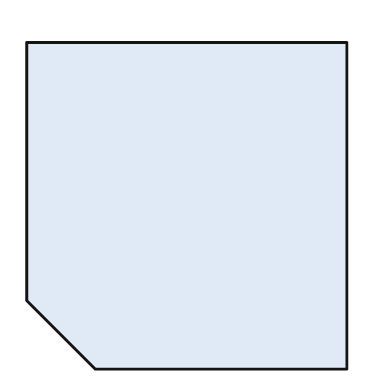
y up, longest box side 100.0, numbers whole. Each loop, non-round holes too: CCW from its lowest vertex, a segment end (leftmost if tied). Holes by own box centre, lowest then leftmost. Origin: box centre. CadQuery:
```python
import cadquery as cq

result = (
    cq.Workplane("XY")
    .moveTo(-28.0, -50.0)
    .lineTo(49.0, -50.0)
    .lineTo(49.0, 50.0)
    .lineTo(-49.0, 50.0)
    .lineTo(-49.0, -29.0)
    .close()
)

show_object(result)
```